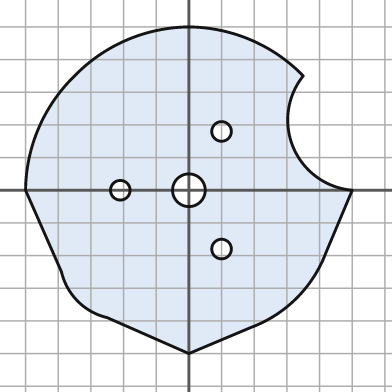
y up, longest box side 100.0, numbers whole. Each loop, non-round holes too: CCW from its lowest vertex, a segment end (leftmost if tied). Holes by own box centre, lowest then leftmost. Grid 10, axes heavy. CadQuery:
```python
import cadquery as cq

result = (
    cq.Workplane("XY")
    .moveTo(0.0, -50.0)
    .lineTo(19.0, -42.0)
    .threePointArc((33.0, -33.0), (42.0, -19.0))
    .lineTo(50.0, 0.0)
    .threePointArc((32.0, 13.0), (35.0, 35.0))
    .threePointArc((19.0, 46.0), (0.0, 50.0))
    .threePointArc((-19.0, 46.0), (-35.0, 35.0))
    .threePointArc((-46.0, 19.0), (-50.0, 0.0))
    .lineTo(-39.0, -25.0)
    .threePointArc((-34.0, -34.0), (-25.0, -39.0))
    .close()
    .moveTo(10.0, -18.0)
    .circle(3.0)
    .moveTo(-21.0, 0.0)
    .circle(3.0)
    .moveTo(0.0, 0.0)
    .circle(5.0)
    .moveTo(10.0, 18.0)
    .circle(3.0)
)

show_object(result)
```